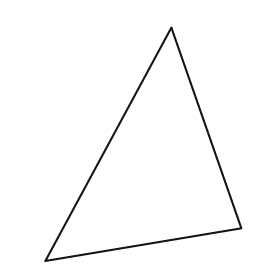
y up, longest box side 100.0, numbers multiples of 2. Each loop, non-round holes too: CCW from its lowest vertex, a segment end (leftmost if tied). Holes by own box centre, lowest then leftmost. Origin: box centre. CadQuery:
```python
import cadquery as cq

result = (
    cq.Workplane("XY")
    .moveTo(-42.0, -50.0)
    .lineTo(42.0, -36.0)
    .lineTo(12.0, 50.0)
    .close()
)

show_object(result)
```